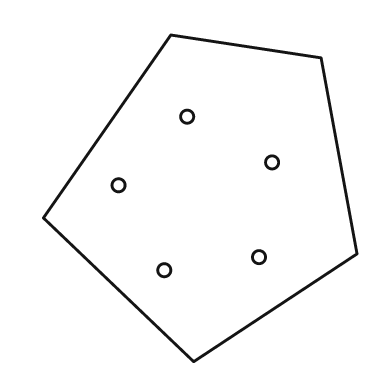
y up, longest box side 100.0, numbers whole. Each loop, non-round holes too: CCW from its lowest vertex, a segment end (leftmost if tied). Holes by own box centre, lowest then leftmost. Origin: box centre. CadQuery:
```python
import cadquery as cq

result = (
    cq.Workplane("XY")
    .moveTo(-2.0, -50.0)
    .lineTo(48.0, -17.0)
    .lineTo(37.0, 43.0)
    .lineTo(-9.0, 50.0)
    .lineTo(-48.0, -6.0)
    .close()
    .moveTo(-11.0, -22.0)
    .circle(2.0)
    .moveTo(18.0, -18.0)
    .circle(2.0)
    .moveTo(-25.0, 4.0)
    .circle(2.0)
    .moveTo(22.0, 11.0)
    .circle(2.0)
    .moveTo(-4.0, 25.0)
    .circle(2.0)
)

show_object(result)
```